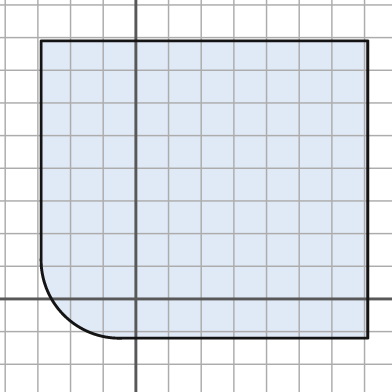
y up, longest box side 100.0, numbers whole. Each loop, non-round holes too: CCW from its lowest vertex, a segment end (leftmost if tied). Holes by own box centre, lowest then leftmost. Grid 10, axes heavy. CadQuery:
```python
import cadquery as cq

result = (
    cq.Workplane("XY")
    .moveTo(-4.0, -12.0)
    .lineTo(71.0, -12.0)
    .lineTo(71.0, 79.0)
    .lineTo(-29.0, 79.0)
    .lineTo(-29.0, 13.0)
    .threePointArc((-22.0, -5.0), (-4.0, -12.0))
    .close()
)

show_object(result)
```